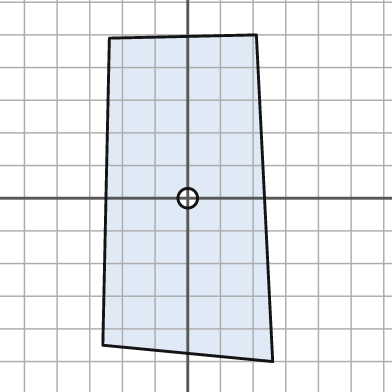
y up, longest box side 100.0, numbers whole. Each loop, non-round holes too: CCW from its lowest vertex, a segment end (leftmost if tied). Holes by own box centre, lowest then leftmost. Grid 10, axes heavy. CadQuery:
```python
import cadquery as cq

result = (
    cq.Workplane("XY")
    .moveTo(26.0, -50.0)
    .lineTo(21.0, 50.0)
    .lineTo(-24.0, 49.0)
    .lineTo(-26.0, -45.0)
    .close()
    .moveTo(0.0, 0.0)
    .circle(3.0)
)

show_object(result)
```